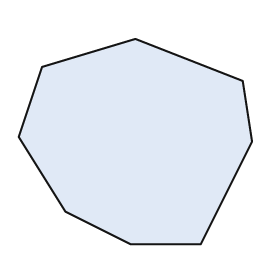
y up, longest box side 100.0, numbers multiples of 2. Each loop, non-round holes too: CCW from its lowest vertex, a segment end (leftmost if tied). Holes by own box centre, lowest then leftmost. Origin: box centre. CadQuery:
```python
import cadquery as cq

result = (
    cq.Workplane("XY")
    .moveTo(-2.0, -44.0)
    .lineTo(28.0, -44.0)
    .lineTo(50.0, 0.0)
    .lineTo(46.0, 26.0)
    .lineTo(0.0, 44.0)
    .lineTo(-40.0, 32.0)
    .lineTo(-50.0, 2.0)
    .lineTo(-30.0, -30.0)
    .close()
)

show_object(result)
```